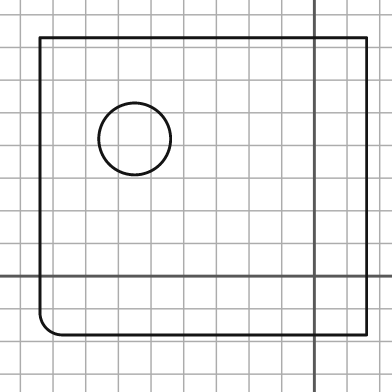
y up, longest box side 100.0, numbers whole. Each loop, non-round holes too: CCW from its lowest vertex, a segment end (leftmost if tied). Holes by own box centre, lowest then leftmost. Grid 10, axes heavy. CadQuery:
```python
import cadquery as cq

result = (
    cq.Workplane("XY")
    .moveTo(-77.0, -18.0)
    .lineTo(16.0, -18.0)
    .lineTo(16.0, 73.0)
    .lineTo(-84.0, 73.0)
    .lineTo(-84.0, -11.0)
    .threePointArc((-82.0, -16.0), (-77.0, -18.0))
    .close()
    .moveTo(-55.0, 42.0)
    .circle(11.0)
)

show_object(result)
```